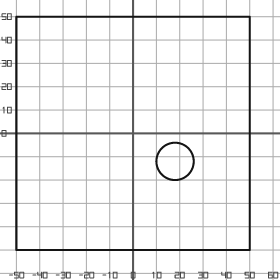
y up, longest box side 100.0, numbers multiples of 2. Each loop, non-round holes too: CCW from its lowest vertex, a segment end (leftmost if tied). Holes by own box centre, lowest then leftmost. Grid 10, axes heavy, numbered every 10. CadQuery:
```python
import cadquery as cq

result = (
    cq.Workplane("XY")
    .moveTo(-50.0, -50.0)
    .lineTo(50.0, -50.0)
    .lineTo(50.0, 50.0)
    .lineTo(-50.0, 50.0)
    .close()
    .moveTo(18.0, -12.0)
    .circle(8.0)
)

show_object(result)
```